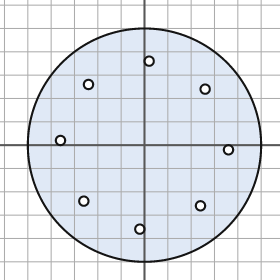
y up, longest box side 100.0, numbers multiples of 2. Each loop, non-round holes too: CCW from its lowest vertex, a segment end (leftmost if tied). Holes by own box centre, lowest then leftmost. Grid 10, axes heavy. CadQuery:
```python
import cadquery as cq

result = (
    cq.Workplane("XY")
    .moveTo(0.0, 0.0)
    .circle(50.0)
    .moveTo(-2.0, -36.0)
    .circle(2.0)
    .moveTo(24.0, -26.0)
    .circle(2.0)
    .moveTo(-26.0, -24.0)
    .circle(2.0)
    .moveTo(36.0, -2.0)
    .circle(2.0)
    .moveTo(-36.0, 2.0)
    .circle(2.0)
    .moveTo(26.0, 24.0)
    .circle(2.0)
    .moveTo(-24.0, 26.0)
    .circle(2.0)
    .moveTo(2.0, 36.0)
    .circle(2.0)
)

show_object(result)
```